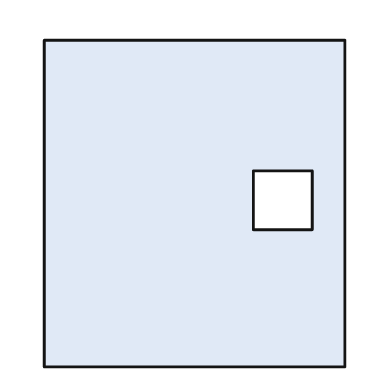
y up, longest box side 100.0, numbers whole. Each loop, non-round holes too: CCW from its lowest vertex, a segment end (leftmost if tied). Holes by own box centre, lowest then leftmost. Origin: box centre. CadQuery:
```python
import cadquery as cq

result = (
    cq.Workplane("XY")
    .moveTo(-46.0, -50.0)
    .lineTo(46.0, -50.0)
    .lineTo(46.0, 50.0)
    .lineTo(-46.0, 50.0)
    .close()
    .moveTo(18.0, -8.0)
    .lineTo(36.0, -8.0)
    .lineTo(36.0, 10.0)
    .lineTo(18.0, 10.0)
    .close()
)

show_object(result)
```